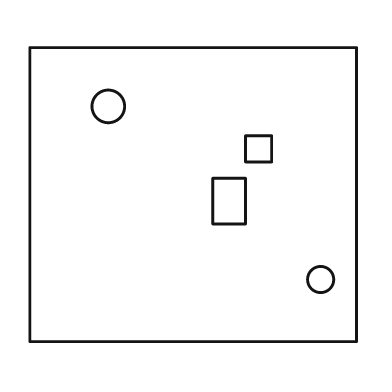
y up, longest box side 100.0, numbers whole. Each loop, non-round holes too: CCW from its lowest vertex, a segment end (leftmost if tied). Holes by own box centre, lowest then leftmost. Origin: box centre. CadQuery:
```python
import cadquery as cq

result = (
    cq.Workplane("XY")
    .moveTo(-50.0, -45.0)
    .lineTo(50.0, -45.0)
    .lineTo(50.0, 45.0)
    .lineTo(-50.0, 45.0)
    .close()
    .moveTo(39.0, -26.0)
    .circle(4.0)
    .moveTo(6.0, -9.0)
    .lineTo(16.0, -9.0)
    .lineTo(16.0, 5.0)
    .lineTo(6.0, 5.0)
    .close()
    .moveTo(16.0, 10.0)
    .lineTo(24.0, 10.0)
    .lineTo(24.0, 18.0)
    .lineTo(16.0, 18.0)
    .close()
    .moveTo(-26.0, 27.0)
    .circle(5.0)
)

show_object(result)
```